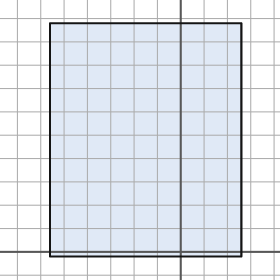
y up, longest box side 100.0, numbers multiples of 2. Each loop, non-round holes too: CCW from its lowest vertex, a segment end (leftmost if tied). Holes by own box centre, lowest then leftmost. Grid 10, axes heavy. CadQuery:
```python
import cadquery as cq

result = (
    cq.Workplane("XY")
    .moveTo(-56.0, -2.0)
    .lineTo(26.0, -2.0)
    .lineTo(26.0, 98.0)
    .lineTo(-56.0, 98.0)
    .close()
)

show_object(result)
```